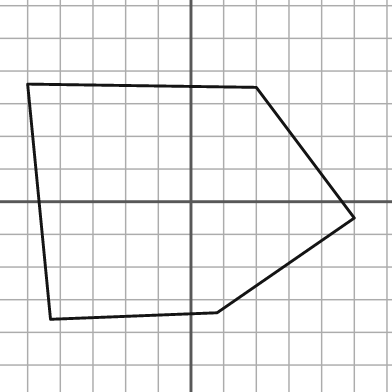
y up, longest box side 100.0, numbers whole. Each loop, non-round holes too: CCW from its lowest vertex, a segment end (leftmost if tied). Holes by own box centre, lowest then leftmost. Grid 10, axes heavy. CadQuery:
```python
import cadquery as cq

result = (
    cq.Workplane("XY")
    .moveTo(-43.0, -36.0)
    .lineTo(8.0, -34.0)
    .lineTo(50.0, -5.0)
    .lineTo(20.0, 35.0)
    .lineTo(-50.0, 36.0)
    .close()
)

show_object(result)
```